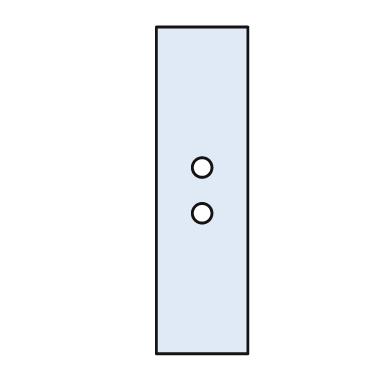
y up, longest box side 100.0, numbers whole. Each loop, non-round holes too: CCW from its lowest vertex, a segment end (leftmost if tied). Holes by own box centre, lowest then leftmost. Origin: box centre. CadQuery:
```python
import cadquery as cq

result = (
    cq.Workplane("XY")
    .moveTo(-14.0, -50.0)
    .lineTo(14.0, -50.0)
    .lineTo(14.0, 50.0)
    .lineTo(-14.0, 50.0)
    .close()
    .moveTo(0.0, -7.0)
    .circle(3.0)
    .moveTo(0.0, 7.0)
    .circle(3.0)
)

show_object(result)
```